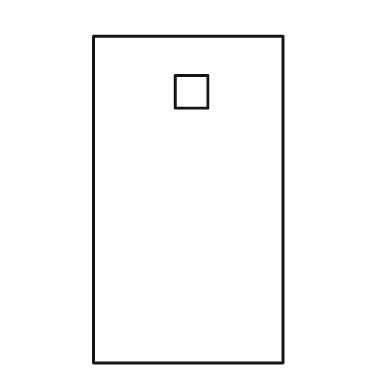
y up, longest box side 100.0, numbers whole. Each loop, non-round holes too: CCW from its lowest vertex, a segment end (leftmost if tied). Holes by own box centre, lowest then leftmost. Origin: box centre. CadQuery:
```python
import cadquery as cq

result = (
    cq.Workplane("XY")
    .moveTo(-29.0, -50.0)
    .lineTo(29.0, -50.0)
    .lineTo(29.0, 50.0)
    .lineTo(-29.0, 50.0)
    .close()
    .moveTo(-4.0, 28.0)
    .lineTo(6.0, 28.0)
    .lineTo(6.0, 38.0)
    .lineTo(-4.0, 38.0)
    .close()
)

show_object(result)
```